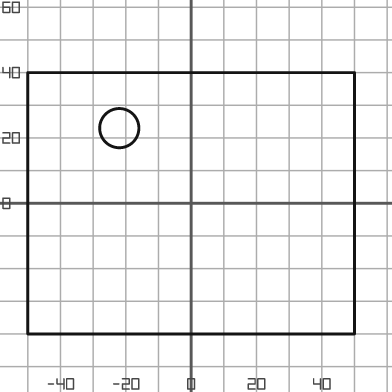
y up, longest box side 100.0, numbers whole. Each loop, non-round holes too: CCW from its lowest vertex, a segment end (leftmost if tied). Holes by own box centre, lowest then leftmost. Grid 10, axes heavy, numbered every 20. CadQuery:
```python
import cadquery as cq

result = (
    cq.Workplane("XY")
    .moveTo(-50.0, -40.0)
    .lineTo(50.0, -40.0)
    .lineTo(50.0, 40.0)
    .lineTo(-50.0, 40.0)
    .close()
    .moveTo(-22.0, 23.0)
    .circle(6.0)
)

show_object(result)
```